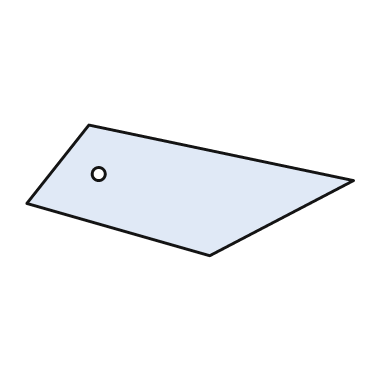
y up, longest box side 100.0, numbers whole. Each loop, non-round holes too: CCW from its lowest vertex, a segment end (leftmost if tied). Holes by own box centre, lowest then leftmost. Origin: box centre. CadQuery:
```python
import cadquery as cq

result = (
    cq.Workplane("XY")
    .moveTo(6.0, -20.0)
    .lineTo(50.0, 3.0)
    .lineTo(-31.0, 20.0)
    .lineTo(-50.0, -4.0)
    .close()
    .moveTo(-28.0, 5.0)
    .circle(2.0)
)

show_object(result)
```